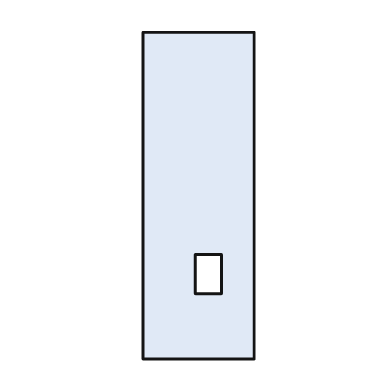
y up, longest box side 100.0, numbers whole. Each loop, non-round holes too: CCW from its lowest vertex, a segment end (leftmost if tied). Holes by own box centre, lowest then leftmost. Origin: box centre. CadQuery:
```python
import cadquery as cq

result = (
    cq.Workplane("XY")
    .moveTo(-17.0, -50.0)
    .lineTo(17.0, -50.0)
    .lineTo(17.0, 50.0)
    .lineTo(-17.0, 50.0)
    .close()
    .moveTo(-1.0, -30.0)
    .lineTo(7.0, -30.0)
    .lineTo(7.0, -18.0)
    .lineTo(-1.0, -18.0)
    .close()
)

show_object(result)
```